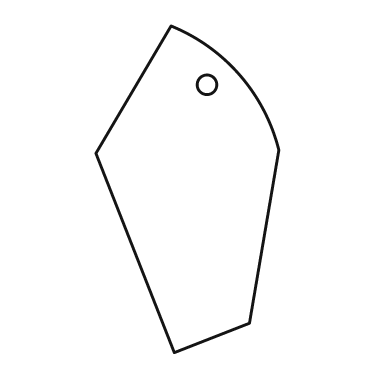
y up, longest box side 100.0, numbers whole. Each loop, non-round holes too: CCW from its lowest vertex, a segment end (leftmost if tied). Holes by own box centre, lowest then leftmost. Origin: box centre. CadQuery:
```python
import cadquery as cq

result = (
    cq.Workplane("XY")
    .moveTo(-4.0, -50.0)
    .lineTo(19.0, -41.0)
    .lineTo(28.0, 12.0)
    .threePointArc((16.0, 35.0), (-5.0, 50.0))
    .lineTo(-28.0, 11.0)
    .close()
    .moveTo(6.0, 32.0)
    .circle(3.0)
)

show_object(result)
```